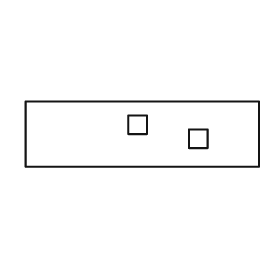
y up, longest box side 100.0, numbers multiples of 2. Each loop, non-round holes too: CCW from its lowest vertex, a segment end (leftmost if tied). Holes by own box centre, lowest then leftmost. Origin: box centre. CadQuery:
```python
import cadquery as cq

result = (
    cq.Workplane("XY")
    .moveTo(-50.0, -14.0)
    .lineTo(50.0, -14.0)
    .lineTo(50.0, 14.0)
    .lineTo(-50.0, 14.0)
    .close()
    .moveTo(20.0, -6.0)
    .lineTo(28.0, -6.0)
    .lineTo(28.0, 2.0)
    .lineTo(20.0, 2.0)
    .close()
    .moveTo(-6.0, 0.0)
    .lineTo(2.0, 0.0)
    .lineTo(2.0, 8.0)
    .lineTo(-6.0, 8.0)
    .close()
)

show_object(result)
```